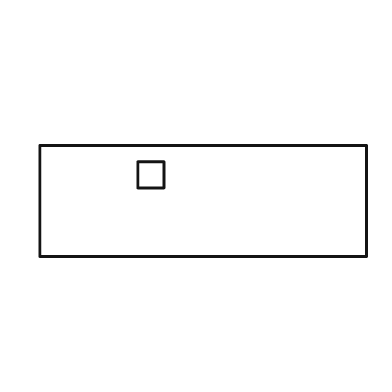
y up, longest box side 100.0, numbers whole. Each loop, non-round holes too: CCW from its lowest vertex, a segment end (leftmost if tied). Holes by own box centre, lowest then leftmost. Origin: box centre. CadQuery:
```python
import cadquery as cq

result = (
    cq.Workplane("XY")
    .moveTo(-50.0, -17.0)
    .lineTo(50.0, -17.0)
    .lineTo(50.0, 17.0)
    .lineTo(-50.0, 17.0)
    .close()
    .moveTo(-20.0, 4.0)
    .lineTo(-12.0, 4.0)
    .lineTo(-12.0, 12.0)
    .lineTo(-20.0, 12.0)
    .close()
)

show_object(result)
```